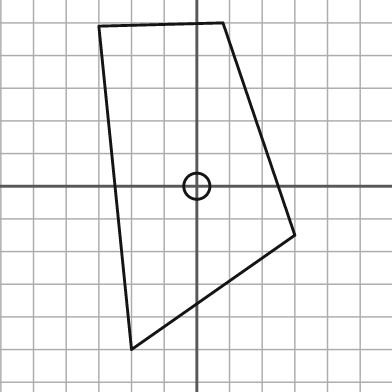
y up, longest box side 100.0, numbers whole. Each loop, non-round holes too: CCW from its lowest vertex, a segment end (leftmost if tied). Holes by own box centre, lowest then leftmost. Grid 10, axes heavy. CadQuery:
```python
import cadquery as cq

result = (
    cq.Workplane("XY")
    .moveTo(-20.0, -50.0)
    .lineTo(30.0, -15.0)
    .lineTo(8.0, 50.0)
    .lineTo(-30.0, 49.0)
    .close()
    .moveTo(0.0, 0.0)
    .circle(4.0)
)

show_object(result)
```